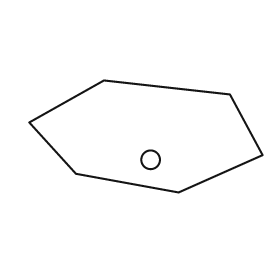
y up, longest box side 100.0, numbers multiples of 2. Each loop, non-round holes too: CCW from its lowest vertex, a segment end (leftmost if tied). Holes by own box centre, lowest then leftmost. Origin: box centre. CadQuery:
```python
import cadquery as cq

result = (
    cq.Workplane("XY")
    .moveTo(14.0, -24.0)
    .lineTo(50.0, -8.0)
    .lineTo(36.0, 18.0)
    .lineTo(-18.0, 24.0)
    .lineTo(-50.0, 6.0)
    .lineTo(-30.0, -16.0)
    .close()
    .moveTo(2.0, -10.0)
    .circle(4.0)
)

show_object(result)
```